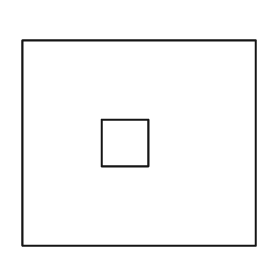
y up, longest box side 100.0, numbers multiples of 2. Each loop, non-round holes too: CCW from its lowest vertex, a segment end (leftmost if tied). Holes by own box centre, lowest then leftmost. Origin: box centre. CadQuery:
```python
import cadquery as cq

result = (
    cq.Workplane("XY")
    .moveTo(-50.0, -44.0)
    .lineTo(50.0, -44.0)
    .lineTo(50.0, 44.0)
    .lineTo(-50.0, 44.0)
    .close()
    .moveTo(-16.0, -10.0)
    .lineTo(4.0, -10.0)
    .lineTo(4.0, 10.0)
    .lineTo(-16.0, 10.0)
    .close()
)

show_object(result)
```